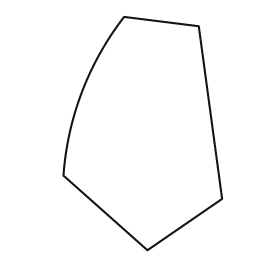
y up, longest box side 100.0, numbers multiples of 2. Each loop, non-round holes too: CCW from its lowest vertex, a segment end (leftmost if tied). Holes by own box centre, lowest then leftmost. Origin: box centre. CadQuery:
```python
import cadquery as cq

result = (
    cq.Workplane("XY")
    .moveTo(2.0, -50.0)
    .lineTo(34.0, -28.0)
    .lineTo(24.0, 46.0)
    .lineTo(-8.0, 50.0)
    .threePointArc((-26.0, 18.0), (-34.0, -18.0))
    .close()
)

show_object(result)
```